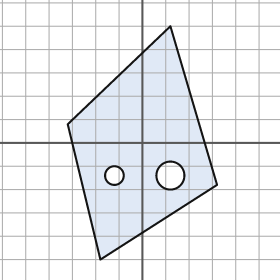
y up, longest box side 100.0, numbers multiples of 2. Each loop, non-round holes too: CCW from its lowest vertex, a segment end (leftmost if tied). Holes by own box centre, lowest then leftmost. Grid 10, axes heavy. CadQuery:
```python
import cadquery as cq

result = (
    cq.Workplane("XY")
    .moveTo(-18.0, -50.0)
    .lineTo(32.0, -18.0)
    .lineTo(12.0, 50.0)
    .lineTo(-32.0, 8.0)
    .close()
    .moveTo(-12.0, -14.0)
    .circle(4.0)
    .moveTo(12.0, -14.0)
    .circle(6.0)
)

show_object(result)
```